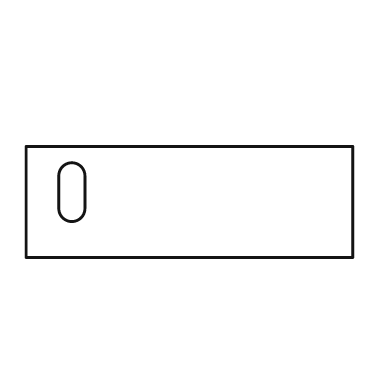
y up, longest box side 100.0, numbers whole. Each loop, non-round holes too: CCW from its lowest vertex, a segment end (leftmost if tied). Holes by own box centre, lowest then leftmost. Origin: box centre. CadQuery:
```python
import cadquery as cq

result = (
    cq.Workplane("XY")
    .moveTo(-50.0, -17.0)
    .lineTo(50.0, -17.0)
    .lineTo(50.0, 17.0)
    .lineTo(-50.0, 17.0)
    .close()
    .moveTo(-40.0, -2.0)
    .threePointArc((-36.0, -6.0), (-32.0, -2.0))
    .lineTo(-32.0, 8.0)
    .threePointArc((-36.0, 12.0), (-40.0, 8.0))
    .close()
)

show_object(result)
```